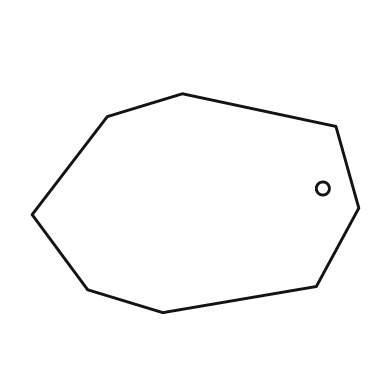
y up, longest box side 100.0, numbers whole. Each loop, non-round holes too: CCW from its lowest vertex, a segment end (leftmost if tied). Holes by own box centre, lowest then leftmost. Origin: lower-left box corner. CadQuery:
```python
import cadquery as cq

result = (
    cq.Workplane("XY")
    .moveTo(40.0, 0.0)
    .lineTo(87.0, 8.0)
    .lineTo(100.0, 32.0)
    .lineTo(93.0, 57.0)
    .lineTo(46.0, 67.0)
    .lineTo(23.0, 60.0)
    .lineTo(0.0, 30.0)
    .lineTo(17.0, 7.0)
    .close()
    .moveTo(89.0, 38.0)
    .circle(2.0)
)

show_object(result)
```